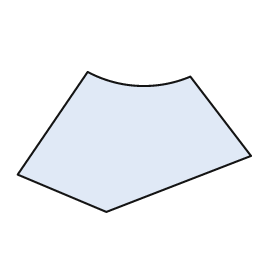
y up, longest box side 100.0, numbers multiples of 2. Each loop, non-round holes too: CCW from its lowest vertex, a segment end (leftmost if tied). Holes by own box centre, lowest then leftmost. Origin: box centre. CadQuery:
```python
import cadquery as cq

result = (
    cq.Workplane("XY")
    .moveTo(-12.0, -30.0)
    .lineTo(50.0, -6.0)
    .lineTo(24.0, 28.0)
    .threePointArc((2.0, 24.0), (-20.0, 30.0))
    .lineTo(-50.0, -14.0)
    .close()
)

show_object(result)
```